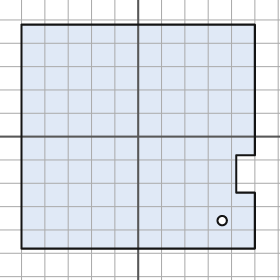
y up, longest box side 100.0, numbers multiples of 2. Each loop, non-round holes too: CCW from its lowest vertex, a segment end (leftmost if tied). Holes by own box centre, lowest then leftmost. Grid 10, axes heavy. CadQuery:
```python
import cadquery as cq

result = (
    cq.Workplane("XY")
    .moveTo(-50.0, -48.0)
    .lineTo(50.0, -48.0)
    .lineTo(50.0, -24.0)
    .lineTo(42.0, -24.0)
    .lineTo(42.0, -8.0)
    .lineTo(50.0, -8.0)
    .lineTo(50.0, 48.0)
    .lineTo(-50.0, 48.0)
    .close()
    .moveTo(36.0, -36.0)
    .circle(2.0)
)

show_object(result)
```